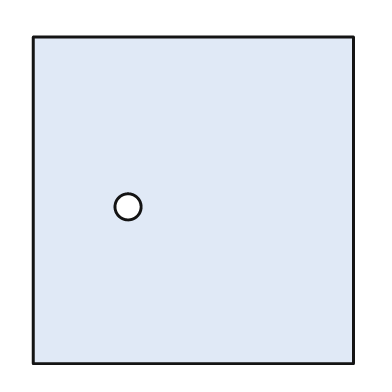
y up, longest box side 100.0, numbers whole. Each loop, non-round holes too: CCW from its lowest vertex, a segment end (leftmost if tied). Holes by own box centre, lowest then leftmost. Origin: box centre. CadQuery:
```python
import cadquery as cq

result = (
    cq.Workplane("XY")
    .moveTo(-49.0, -50.0)
    .lineTo(49.0, -50.0)
    .lineTo(49.0, 50.0)
    .lineTo(-49.0, 50.0)
    .close()
    .moveTo(-20.0, -2.0)
    .circle(4.0)
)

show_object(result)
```